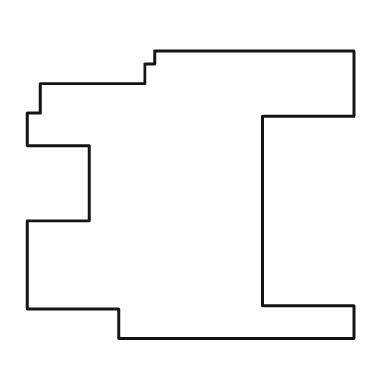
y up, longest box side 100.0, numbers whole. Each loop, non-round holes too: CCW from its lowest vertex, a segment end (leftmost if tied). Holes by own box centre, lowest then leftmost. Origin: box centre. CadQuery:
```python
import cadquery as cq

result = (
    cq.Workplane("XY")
    .moveTo(-22.0, -44.0)
    .lineTo(50.0, -44.0)
    .lineTo(50.0, -34.0)
    .lineTo(22.0, -34.0)
    .lineTo(22.0, 24.0)
    .lineTo(50.0, 24.0)
    .lineTo(50.0, 44.0)
    .lineTo(-11.0, 44.0)
    .lineTo(-11.0, 40.0)
    .lineTo(-14.0, 40.0)
    .lineTo(-14.0, 34.0)
    .lineTo(-46.0, 34.0)
    .lineTo(-46.0, 25.0)
    .lineTo(-50.0, 25.0)
    .lineTo(-50.0, 15.0)
    .lineTo(-31.0, 15.0)
    .lineTo(-31.0, -8.0)
    .lineTo(-50.0, -8.0)
    .lineTo(-50.0, -35.0)
    .lineTo(-22.0, -35.0)
    .close()
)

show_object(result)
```